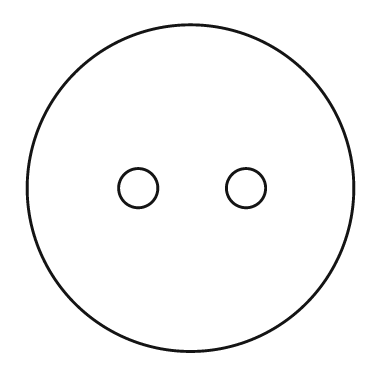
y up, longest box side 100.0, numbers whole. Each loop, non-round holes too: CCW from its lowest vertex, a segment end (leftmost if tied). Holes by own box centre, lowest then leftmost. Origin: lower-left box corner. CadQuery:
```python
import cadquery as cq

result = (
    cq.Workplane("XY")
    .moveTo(50.0, 50.0)
    .circle(50.0)
    .moveTo(34.0, 50.0)
    .circle(6.0)
    .moveTo(67.0, 50.0)
    .circle(6.0)
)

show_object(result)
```